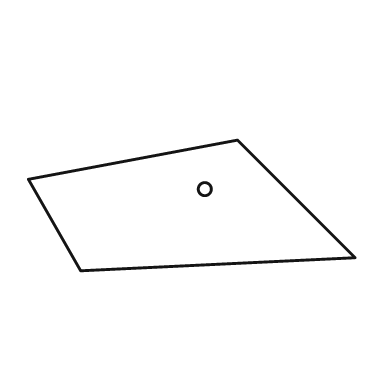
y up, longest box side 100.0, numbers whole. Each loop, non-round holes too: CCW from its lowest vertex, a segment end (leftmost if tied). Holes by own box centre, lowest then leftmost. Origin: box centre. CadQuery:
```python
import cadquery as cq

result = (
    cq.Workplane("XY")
    .moveTo(-34.0, -20.0)
    .lineTo(50.0, -16.0)
    .lineTo(14.0, 20.0)
    .lineTo(-50.0, 8.0)
    .close()
    .moveTo(4.0, 5.0)
    .circle(2.0)
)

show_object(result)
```